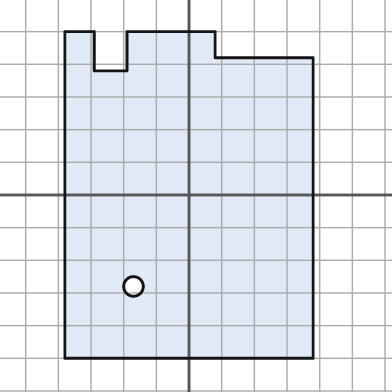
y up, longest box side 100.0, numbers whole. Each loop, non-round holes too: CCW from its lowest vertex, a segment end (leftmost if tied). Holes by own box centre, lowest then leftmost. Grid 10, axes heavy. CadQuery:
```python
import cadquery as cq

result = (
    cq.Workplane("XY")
    .moveTo(-38.0, -50.0)
    .lineTo(38.0, -50.0)
    .lineTo(38.0, 42.0)
    .lineTo(8.0, 42.0)
    .lineTo(8.0, 50.0)
    .lineTo(-19.0, 50.0)
    .lineTo(-19.0, 38.0)
    .lineTo(-29.0, 38.0)
    .lineTo(-29.0, 50.0)
    .lineTo(-38.0, 50.0)
    .close()
    .moveTo(-17.0, -28.0)
    .circle(3.0)
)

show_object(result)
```